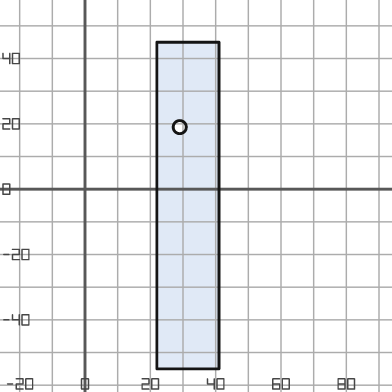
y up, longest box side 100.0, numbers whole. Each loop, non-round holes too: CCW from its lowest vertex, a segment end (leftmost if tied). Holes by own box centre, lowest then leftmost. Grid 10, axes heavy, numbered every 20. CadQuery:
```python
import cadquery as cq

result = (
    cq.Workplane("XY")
    .moveTo(22.0, -55.0)
    .lineTo(41.0, -55.0)
    .lineTo(41.0, 45.0)
    .lineTo(22.0, 45.0)
    .close()
    .moveTo(29.0, 19.0)
    .circle(2.0)
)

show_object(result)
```